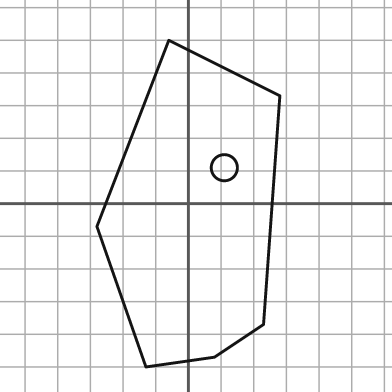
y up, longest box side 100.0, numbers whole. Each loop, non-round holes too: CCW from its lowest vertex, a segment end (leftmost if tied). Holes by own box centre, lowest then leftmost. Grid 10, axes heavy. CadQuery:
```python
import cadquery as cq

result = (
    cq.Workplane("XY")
    .moveTo(-13.0, -50.0)
    .lineTo(8.0, -47.0)
    .lineTo(23.0, -37.0)
    .lineTo(28.0, 33.0)
    .lineTo(-6.0, 50.0)
    .lineTo(-28.0, -7.0)
    .close()
    .moveTo(11.0, 11.0)
    .circle(4.0)
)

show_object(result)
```